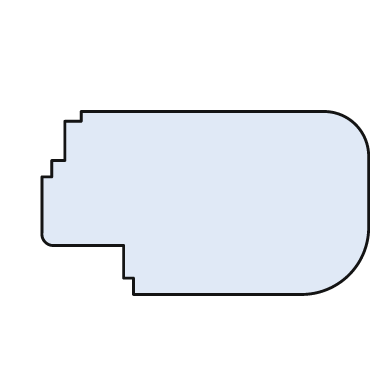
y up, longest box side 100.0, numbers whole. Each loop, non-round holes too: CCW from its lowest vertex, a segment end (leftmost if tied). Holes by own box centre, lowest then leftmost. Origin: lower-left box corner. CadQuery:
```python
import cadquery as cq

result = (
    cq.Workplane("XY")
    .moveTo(28.0, 0.0)
    .lineTo(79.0, 0.0)
    .threePointArc((94.0, 6.0), (100.0, 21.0))
    .lineTo(100.0, 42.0)
    .threePointArc((96.0, 52.0), (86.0, 56.0))
    .lineTo(12.0, 56.0)
    .lineTo(12.0, 53.0)
    .lineTo(7.0, 53.0)
    .lineTo(7.0, 41.0)
    .lineTo(3.0, 41.0)
    .lineTo(3.0, 36.0)
    .lineTo(0.0, 36.0)
    .lineTo(0.0, 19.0)
    .threePointArc((1.0, 16.0), (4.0, 15.0))
    .lineTo(25.0, 15.0)
    .lineTo(25.0, 5.0)
    .lineTo(28.0, 5.0)
    .close()
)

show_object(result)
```